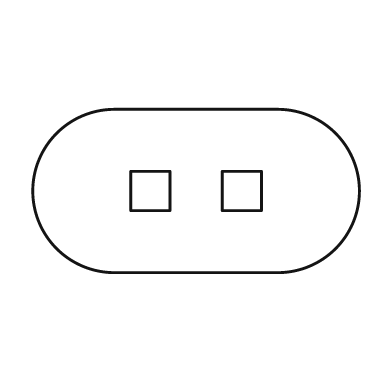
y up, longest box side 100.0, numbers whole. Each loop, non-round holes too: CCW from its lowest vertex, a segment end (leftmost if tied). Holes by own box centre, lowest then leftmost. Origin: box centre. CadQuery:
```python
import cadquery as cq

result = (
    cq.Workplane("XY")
    .moveTo(-25.0, -25.0)
    .lineTo(25.0, -25.0)
    .threePointArc((50.0, 0.0), (25.0, 25.0))
    .lineTo(-25.0, 25.0)
    .threePointArc((-50.0, 0.0), (-25.0, -25.0))
    .close()
    .moveTo(-20.0, -6.0)
    .lineTo(-8.0, -6.0)
    .lineTo(-8.0, 6.0)
    .lineTo(-20.0, 6.0)
    .close()
    .moveTo(8.0, -6.0)
    .lineTo(20.0, -6.0)
    .lineTo(20.0, 6.0)
    .lineTo(8.0, 6.0)
    .close()
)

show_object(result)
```